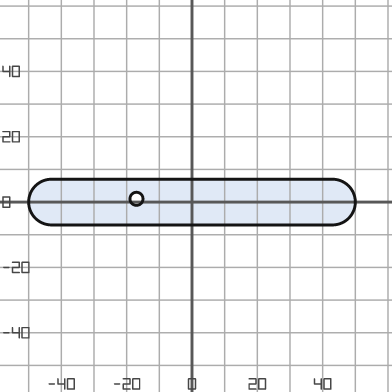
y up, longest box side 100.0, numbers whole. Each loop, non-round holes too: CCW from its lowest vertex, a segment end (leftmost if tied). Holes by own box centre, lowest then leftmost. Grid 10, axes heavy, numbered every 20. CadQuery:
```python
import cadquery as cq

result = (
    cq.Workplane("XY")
    .moveTo(-43.0, -7.0)
    .lineTo(43.0, -7.0)
    .threePointArc((50.0, 0.0), (43.0, 7.0))
    .lineTo(-43.0, 7.0)
    .threePointArc((-50.0, 0.0), (-43.0, -7.0))
    .close()
    .moveTo(-17.0, 1.0)
    .circle(2.0)
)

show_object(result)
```